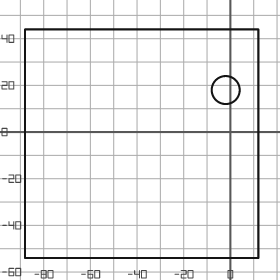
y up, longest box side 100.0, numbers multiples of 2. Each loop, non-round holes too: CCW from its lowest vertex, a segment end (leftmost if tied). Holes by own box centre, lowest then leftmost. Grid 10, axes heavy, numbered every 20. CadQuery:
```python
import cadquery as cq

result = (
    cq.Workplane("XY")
    .moveTo(-88.0, -54.0)
    .lineTo(12.0, -54.0)
    .lineTo(12.0, 44.0)
    .lineTo(-88.0, 44.0)
    .close()
    .moveTo(-2.0, 18.0)
    .circle(6.0)
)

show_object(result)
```